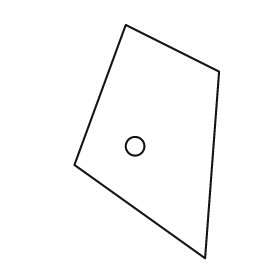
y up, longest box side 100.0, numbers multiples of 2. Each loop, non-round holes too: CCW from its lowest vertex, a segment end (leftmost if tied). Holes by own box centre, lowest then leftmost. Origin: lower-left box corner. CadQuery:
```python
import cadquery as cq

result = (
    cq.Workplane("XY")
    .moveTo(56.0, 0.0)
    .lineTo(62.0, 80.0)
    .lineTo(22.0, 100.0)
    .lineTo(0.0, 40.0)
    .close()
    .moveTo(26.0, 48.0)
    .circle(4.0)
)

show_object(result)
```